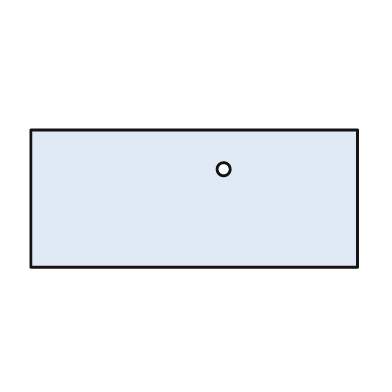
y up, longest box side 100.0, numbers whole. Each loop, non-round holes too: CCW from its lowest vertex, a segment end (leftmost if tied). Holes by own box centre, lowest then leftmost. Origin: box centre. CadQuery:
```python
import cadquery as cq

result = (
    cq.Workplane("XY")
    .moveTo(-50.0, -21.0)
    .lineTo(50.0, -21.0)
    .lineTo(50.0, 21.0)
    .lineTo(-50.0, 21.0)
    .close()
    .moveTo(9.0, 9.0)
    .circle(2.0)
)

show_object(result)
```